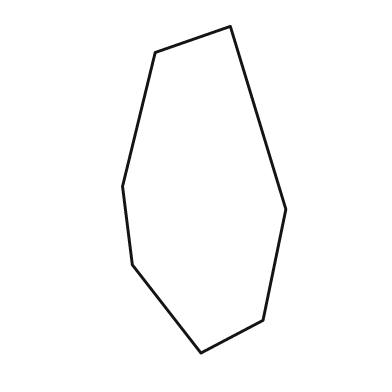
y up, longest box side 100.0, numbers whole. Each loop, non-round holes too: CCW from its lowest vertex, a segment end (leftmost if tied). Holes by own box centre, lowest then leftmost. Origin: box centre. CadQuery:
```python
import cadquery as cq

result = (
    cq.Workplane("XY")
    .moveTo(-1.0, -50.0)
    .lineTo(18.0, -40.0)
    .lineTo(25.0, -6.0)
    .lineTo(8.0, 50.0)
    .lineTo(-15.0, 42.0)
    .lineTo(-25.0, 1.0)
    .lineTo(-22.0, -23.0)
    .close()
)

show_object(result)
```